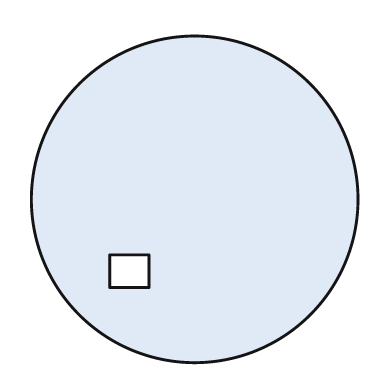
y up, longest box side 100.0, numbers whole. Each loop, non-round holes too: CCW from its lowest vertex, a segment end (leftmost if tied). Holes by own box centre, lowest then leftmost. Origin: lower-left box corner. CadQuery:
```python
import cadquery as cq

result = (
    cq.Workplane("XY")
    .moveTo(50.0, 50.0)
    .circle(50.0)
    .moveTo(24.0, 23.0)
    .lineTo(36.0, 23.0)
    .lineTo(36.0, 33.0)
    .lineTo(24.0, 33.0)
    .close()
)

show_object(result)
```